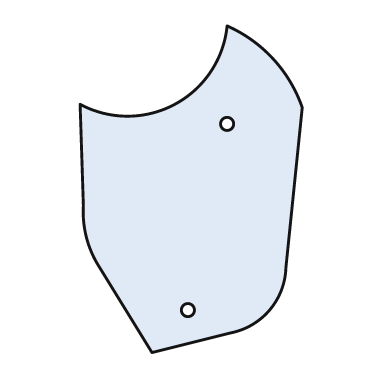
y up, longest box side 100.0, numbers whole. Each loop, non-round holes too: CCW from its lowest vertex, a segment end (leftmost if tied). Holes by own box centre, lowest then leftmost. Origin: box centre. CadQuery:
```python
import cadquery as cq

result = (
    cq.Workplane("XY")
    .moveTo(-12.0, -50.0)
    .lineTo(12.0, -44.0)
    .threePointArc((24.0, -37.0), (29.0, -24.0))
    .lineTo(34.0, 25.0)
    .threePointArc((25.0, 40.0), (11.0, 50.0))
    .threePointArc((-5.0, 26.0), (-34.0, 26.0))
    .lineTo(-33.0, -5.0)
    .threePointArc((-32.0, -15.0), (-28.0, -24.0))
    .close()
    .moveTo(-1.0, -37.0)
    .circle(2.0)
    .moveTo(11.0, 20.0)
    .circle(2.0)
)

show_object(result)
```